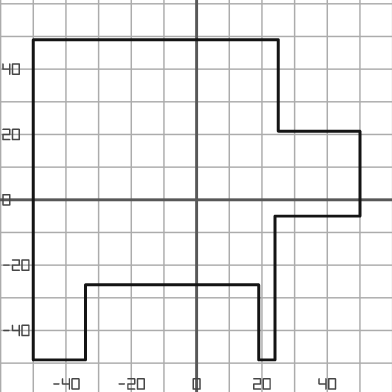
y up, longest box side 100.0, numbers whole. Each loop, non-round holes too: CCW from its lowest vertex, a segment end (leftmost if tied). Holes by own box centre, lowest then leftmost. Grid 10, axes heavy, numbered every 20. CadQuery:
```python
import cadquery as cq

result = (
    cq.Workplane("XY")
    .moveTo(-50.0, -49.0)
    .lineTo(-34.0, -49.0)
    .lineTo(-34.0, -26.0)
    .lineTo(19.0, -26.0)
    .lineTo(19.0, -49.0)
    .lineTo(24.0, -49.0)
    .lineTo(24.0, -5.0)
    .lineTo(50.0, -5.0)
    .lineTo(50.0, 21.0)
    .lineTo(25.0, 21.0)
    .lineTo(25.0, 49.0)
    .lineTo(-50.0, 49.0)
    .close()
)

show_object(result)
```